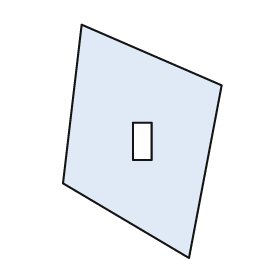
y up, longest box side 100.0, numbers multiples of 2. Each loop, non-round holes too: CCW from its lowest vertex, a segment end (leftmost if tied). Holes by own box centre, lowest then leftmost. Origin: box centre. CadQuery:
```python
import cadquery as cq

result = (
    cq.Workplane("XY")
    .moveTo(20.0, -50.0)
    .lineTo(34.0, 24.0)
    .lineTo(-26.0, 50.0)
    .lineTo(-34.0, -18.0)
    .close()
    .moveTo(-4.0, -8.0)
    .lineTo(4.0, -8.0)
    .lineTo(4.0, 8.0)
    .lineTo(-4.0, 8.0)
    .close()
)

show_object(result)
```